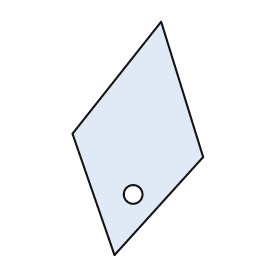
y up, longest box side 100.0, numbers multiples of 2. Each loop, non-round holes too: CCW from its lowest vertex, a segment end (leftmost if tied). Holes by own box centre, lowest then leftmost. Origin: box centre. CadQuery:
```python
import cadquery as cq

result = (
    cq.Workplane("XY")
    .moveTo(-10.0, -50.0)
    .lineTo(28.0, -8.0)
    .lineTo(10.0, 50.0)
    .lineTo(-28.0, 2.0)
    .close()
    .moveTo(-2.0, -24.0)
    .circle(4.0)
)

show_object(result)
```